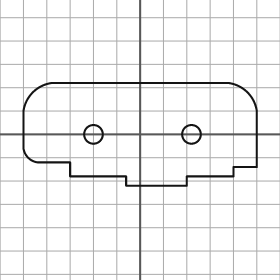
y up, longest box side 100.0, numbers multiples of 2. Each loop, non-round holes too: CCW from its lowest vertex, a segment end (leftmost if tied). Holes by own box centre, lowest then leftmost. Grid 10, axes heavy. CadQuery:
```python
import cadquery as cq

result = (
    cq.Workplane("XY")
    .moveTo(-6.0, -22.0)
    .lineTo(20.0, -22.0)
    .lineTo(20.0, -18.0)
    .lineTo(40.0, -18.0)
    .lineTo(40.0, -14.0)
    .lineTo(50.0, -14.0)
    .lineTo(50.0, 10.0)
    .threePointArc((46.0, 18.0), (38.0, 22.0))
    .lineTo(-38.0, 22.0)
    .threePointArc((-46.0, 18.0), (-50.0, 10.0))
    .lineTo(-50.0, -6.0)
    .threePointArc((-48.0, -10.0), (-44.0, -12.0))
    .lineTo(-30.0, -12.0)
    .lineTo(-30.0, -18.0)
    .lineTo(-6.0, -18.0)
    .close()
    .moveTo(-20.0, 0.0)
    .circle(4.0)
    .moveTo(22.0, 0.0)
    .circle(4.0)
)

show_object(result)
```